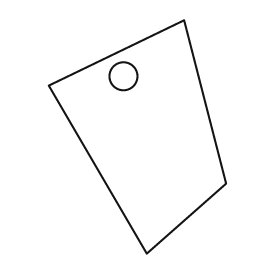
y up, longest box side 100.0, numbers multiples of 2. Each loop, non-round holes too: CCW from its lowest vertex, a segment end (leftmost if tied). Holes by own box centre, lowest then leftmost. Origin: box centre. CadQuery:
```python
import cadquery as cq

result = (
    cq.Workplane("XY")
    .moveTo(4.0, -50.0)
    .lineTo(38.0, -20.0)
    .lineTo(20.0, 50.0)
    .lineTo(-38.0, 22.0)
    .close()
    .moveTo(-6.0, 26.0)
    .circle(6.0)
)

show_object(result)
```